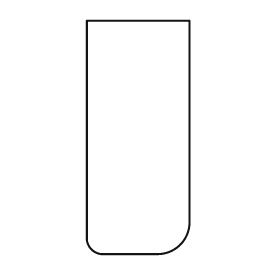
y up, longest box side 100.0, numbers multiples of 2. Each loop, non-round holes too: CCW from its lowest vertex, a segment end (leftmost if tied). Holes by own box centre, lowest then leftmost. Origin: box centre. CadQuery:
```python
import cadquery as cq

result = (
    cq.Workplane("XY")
    .moveTo(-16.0, -50.0)
    .lineTo(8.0, -50.0)
    .threePointArc((18.0, -46.0), (22.0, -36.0))
    .lineTo(22.0, 50.0)
    .lineTo(-22.0, 50.0)
    .lineTo(-22.0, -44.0)
    .threePointArc((-20.0, -48.0), (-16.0, -50.0))
    .close()
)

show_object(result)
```